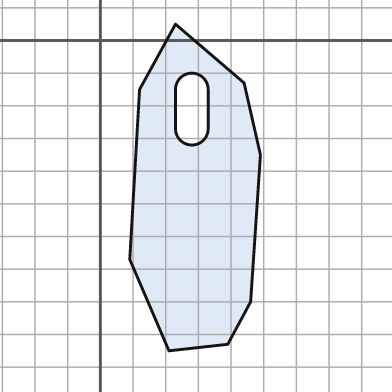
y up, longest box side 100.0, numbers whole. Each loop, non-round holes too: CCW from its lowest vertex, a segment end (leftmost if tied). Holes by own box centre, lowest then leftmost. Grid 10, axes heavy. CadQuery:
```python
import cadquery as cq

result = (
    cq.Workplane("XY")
    .moveTo(21.0, -95.0)
    .lineTo(39.0, -93.0)
    .lineTo(46.0, -80.0)
    .lineTo(49.0, -35.0)
    .lineTo(44.0, -13.0)
    .lineTo(23.0, 5.0)
    .lineTo(12.0, -15.0)
    .lineTo(9.0, -67.0)
    .close()
    .moveTo(23.0, -27.0)
    .threePointArc((28.0, -32.0), (33.0, -27.0))
    .lineTo(33.0, -15.0)
    .threePointArc((28.0, -10.0), (23.0, -15.0))
    .close()
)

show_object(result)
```